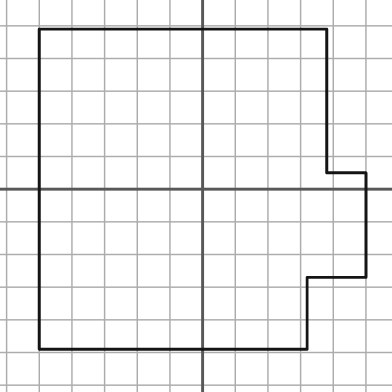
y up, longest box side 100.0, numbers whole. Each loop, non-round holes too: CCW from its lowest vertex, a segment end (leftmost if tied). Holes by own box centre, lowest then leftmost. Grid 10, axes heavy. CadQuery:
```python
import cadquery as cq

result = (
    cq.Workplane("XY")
    .moveTo(-50.0, -49.0)
    .lineTo(32.0, -49.0)
    .lineTo(32.0, -27.0)
    .lineTo(50.0, -27.0)
    .lineTo(50.0, 5.0)
    .lineTo(38.0, 5.0)
    .lineTo(38.0, 49.0)
    .lineTo(-50.0, 49.0)
    .close()
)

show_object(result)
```